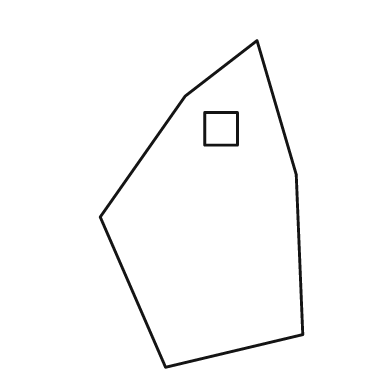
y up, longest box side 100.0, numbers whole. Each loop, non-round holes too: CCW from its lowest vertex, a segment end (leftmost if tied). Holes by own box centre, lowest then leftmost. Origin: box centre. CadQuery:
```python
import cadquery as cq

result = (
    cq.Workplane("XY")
    .moveTo(-11.0, -50.0)
    .lineTo(31.0, -40.0)
    .lineTo(29.0, 9.0)
    .lineTo(17.0, 50.0)
    .lineTo(-5.0, 33.0)
    .lineTo(-31.0, -4.0)
    .close()
    .moveTo(1.0, 18.0)
    .lineTo(11.0, 18.0)
    .lineTo(11.0, 28.0)
    .lineTo(1.0, 28.0)
    .close()
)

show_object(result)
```